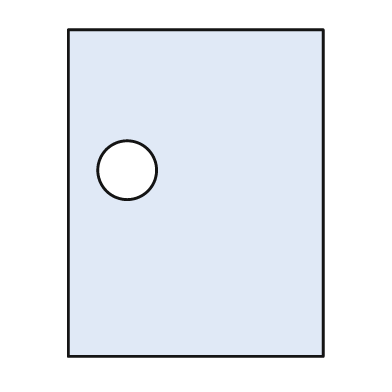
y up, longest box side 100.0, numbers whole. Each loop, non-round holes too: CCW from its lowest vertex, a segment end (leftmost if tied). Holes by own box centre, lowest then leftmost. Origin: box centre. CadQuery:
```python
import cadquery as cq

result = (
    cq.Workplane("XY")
    .moveTo(-39.0, -50.0)
    .lineTo(39.0, -50.0)
    .lineTo(39.0, 50.0)
    .lineTo(-39.0, 50.0)
    .close()
    .moveTo(-21.0, 7.0)
    .circle(9.0)
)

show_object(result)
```